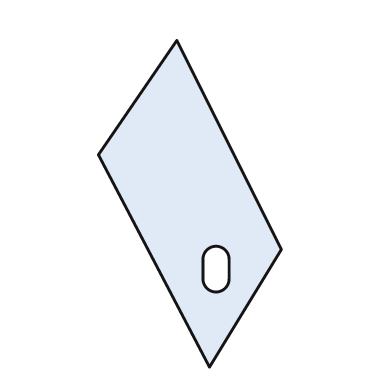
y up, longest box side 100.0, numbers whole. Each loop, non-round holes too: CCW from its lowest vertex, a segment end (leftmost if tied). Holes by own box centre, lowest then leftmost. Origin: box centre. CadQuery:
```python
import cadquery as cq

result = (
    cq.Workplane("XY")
    .moveTo(6.0, -50.0)
    .lineTo(28.0, -14.0)
    .lineTo(-4.0, 50.0)
    .lineTo(-28.0, 15.0)
    .close()
    .moveTo(4.0, -23.0)
    .threePointArc((8.0, -27.0), (12.0, -23.0))
    .lineTo(12.0, -17.0)
    .threePointArc((8.0, -13.0), (4.0, -17.0))
    .close()
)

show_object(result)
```